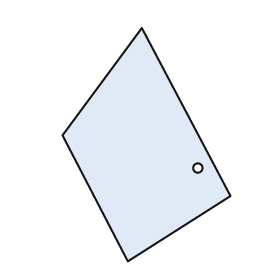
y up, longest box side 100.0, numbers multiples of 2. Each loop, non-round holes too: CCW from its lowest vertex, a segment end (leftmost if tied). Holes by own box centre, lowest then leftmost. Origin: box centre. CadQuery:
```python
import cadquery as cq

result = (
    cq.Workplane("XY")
    .moveTo(-8.0, -50.0)
    .lineTo(36.0, -22.0)
    .lineTo(-2.0, 50.0)
    .lineTo(-36.0, 4.0)
    .close()
    .moveTo(22.0, -10.0)
    .circle(2.0)
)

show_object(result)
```